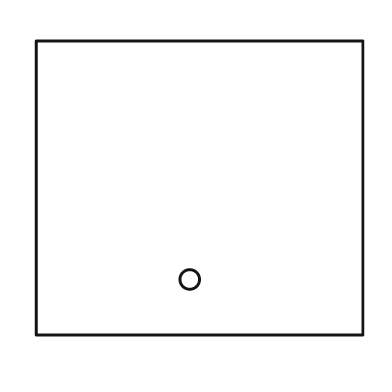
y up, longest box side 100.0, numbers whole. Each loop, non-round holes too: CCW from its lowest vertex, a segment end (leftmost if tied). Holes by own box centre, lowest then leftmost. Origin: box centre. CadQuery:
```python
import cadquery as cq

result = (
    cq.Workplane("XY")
    .moveTo(-50.0, -45.0)
    .lineTo(50.0, -45.0)
    .lineTo(50.0, 45.0)
    .lineTo(-50.0, 45.0)
    .close()
    .moveTo(-3.0, -28.0)
    .circle(3.0)
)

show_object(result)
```